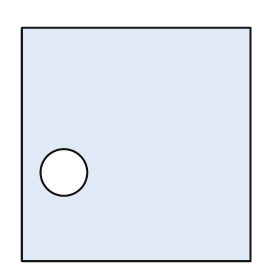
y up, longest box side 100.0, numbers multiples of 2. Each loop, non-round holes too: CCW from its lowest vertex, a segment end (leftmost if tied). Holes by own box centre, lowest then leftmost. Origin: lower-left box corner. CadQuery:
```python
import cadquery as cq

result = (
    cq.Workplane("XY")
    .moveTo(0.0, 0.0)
    .lineTo(98.0, 0.0)
    .lineTo(98.0, 100.0)
    .lineTo(0.0, 100.0)
    .close()
    .moveTo(18.0, 38.0)
    .circle(10.0)
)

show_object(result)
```